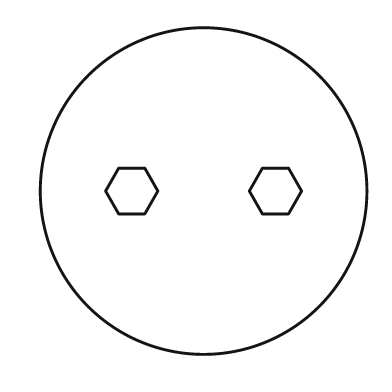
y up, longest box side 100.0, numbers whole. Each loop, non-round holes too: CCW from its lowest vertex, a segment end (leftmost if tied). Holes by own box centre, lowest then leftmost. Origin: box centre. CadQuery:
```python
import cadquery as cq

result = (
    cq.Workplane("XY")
    .moveTo(0.0, 0.0)
    .circle(50.0)
    .moveTo(-26.0, -7.0)
    .lineTo(-18.0, -7.0)
    .lineTo(-14.0, 0.0)
    .lineTo(-18.0, 7.0)
    .lineTo(-26.0, 7.0)
    .lineTo(-30.0, 0.0)
    .close()
    .moveTo(18.0, -7.0)
    .lineTo(26.0, -7.0)
    .lineTo(30.0, 0.0)
    .lineTo(26.0, 7.0)
    .lineTo(18.0, 7.0)
    .lineTo(14.0, 0.0)
    .close()
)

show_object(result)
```